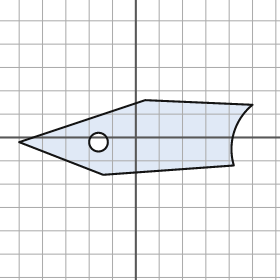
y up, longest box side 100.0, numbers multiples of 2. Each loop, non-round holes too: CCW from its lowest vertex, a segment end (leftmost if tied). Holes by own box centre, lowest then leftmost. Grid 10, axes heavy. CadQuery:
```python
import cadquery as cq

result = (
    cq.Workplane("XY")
    .moveTo(-14.0, -16.0)
    .lineTo(42.0, -12.0)
    .threePointArc((42.0, 2.0), (50.0, 14.0))
    .lineTo(4.0, 16.0)
    .lineTo(-50.0, -2.0)
    .close()
    .moveTo(-16.0, -2.0)
    .circle(4.0)
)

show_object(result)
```